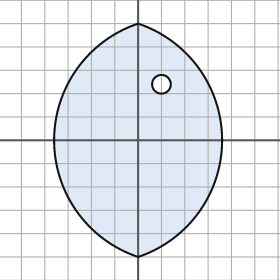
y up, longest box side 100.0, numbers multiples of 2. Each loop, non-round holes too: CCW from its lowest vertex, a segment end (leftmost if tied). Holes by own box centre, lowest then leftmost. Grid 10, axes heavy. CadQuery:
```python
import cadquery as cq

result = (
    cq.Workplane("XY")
    .moveTo(0.0, -50.0)
    .threePointArc((36.0, 0.0), (0.0, 50.0))
    .threePointArc((-36.0, 0.0), (0.0, -50.0))
    .close()
    .moveTo(10.0, 24.0)
    .circle(4.0)
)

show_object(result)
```